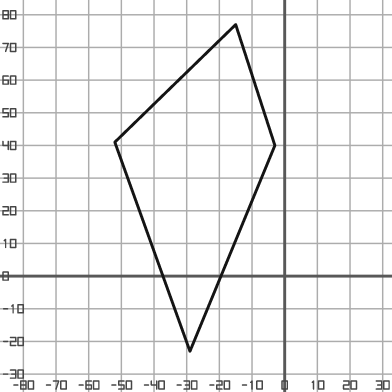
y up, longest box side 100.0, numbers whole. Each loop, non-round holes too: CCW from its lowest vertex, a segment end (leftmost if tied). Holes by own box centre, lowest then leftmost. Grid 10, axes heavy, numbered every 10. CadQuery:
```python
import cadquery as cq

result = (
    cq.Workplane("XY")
    .moveTo(-29.0, -23.0)
    .lineTo(-3.0, 40.0)
    .lineTo(-15.0, 77.0)
    .lineTo(-52.0, 41.0)
    .close()
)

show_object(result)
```